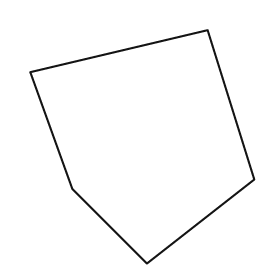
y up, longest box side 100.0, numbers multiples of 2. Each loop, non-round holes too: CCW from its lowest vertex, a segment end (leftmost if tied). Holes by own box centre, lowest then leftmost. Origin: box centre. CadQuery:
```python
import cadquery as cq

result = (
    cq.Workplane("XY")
    .moveTo(2.0, -50.0)
    .lineTo(48.0, -14.0)
    .lineTo(28.0, 50.0)
    .lineTo(-48.0, 32.0)
    .lineTo(-30.0, -18.0)
    .close()
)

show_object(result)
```